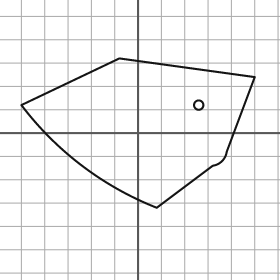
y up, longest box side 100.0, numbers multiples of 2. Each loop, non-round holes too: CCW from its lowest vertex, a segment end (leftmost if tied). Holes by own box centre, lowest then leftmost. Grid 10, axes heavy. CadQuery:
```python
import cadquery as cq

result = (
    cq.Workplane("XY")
    .moveTo(8.0, -32.0)
    .lineTo(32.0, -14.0)
    .threePointArc((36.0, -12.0), (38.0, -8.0))
    .lineTo(50.0, 24.0)
    .lineTo(-8.0, 32.0)
    .lineTo(-50.0, 12.0)
    .threePointArc((-24.0, -14.0), (8.0, -32.0))
    .close()
    .moveTo(26.0, 12.0)
    .circle(2.0)
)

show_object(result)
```